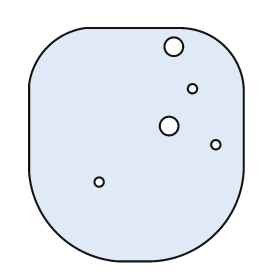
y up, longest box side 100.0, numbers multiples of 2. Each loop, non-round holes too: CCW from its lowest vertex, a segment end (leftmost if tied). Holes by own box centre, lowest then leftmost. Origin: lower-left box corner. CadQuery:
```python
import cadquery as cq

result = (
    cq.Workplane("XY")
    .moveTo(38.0, 0.0)
    .lineTo(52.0, 0.0)
    .threePointArc((80.0, 12.0), (92.0, 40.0))
    .lineTo(92.0, 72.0)
    .threePointArc((84.0, 92.0), (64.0, 100.0))
    .lineTo(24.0, 100.0)
    .threePointArc((8.0, 92.0), (0.0, 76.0))
    .lineTo(0.0, 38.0)
    .threePointArc((12.0, 12.0), (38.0, 0.0))
    .close()
    .moveTo(30.0, 34.0)
    .circle(2.0)
    .moveTo(80.0, 50.0)
    .circle(2.0)
    .moveTo(60.0, 58.0)
    .circle(4.0)
    .moveTo(70.0, 74.0)
    .circle(2.0)
    .moveTo(62.0, 92.0)
    .circle(4.0)
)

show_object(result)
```